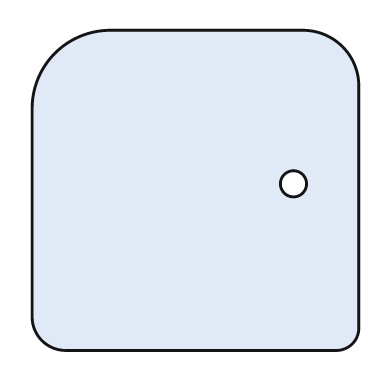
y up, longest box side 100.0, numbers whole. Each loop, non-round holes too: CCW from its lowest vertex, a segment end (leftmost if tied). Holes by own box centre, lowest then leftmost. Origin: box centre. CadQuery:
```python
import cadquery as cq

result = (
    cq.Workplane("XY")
    .moveTo(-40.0, -49.0)
    .lineTo(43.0, -49.0)
    .threePointArc((48.0, -47.0), (50.0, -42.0))
    .lineTo(50.0, 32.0)
    .threePointArc((45.0, 44.0), (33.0, 49.0))
    .lineTo(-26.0, 49.0)
    .threePointArc((-43.0, 42.0), (-50.0, 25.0))
    .lineTo(-50.0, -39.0)
    .threePointArc((-47.0, -46.0), (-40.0, -49.0))
    .close()
    .moveTo(30.0, 2.0)
    .circle(4.0)
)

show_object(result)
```